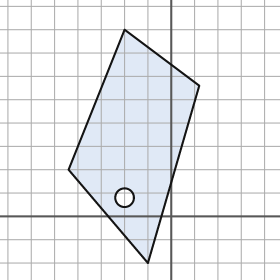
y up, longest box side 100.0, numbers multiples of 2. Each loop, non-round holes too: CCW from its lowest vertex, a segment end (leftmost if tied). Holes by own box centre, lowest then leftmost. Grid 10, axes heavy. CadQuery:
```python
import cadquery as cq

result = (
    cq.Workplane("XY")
    .moveTo(-10.0, -20.0)
    .lineTo(12.0, 56.0)
    .lineTo(-20.0, 80.0)
    .lineTo(-44.0, 20.0)
    .close()
    .moveTo(-20.0, 8.0)
    .circle(4.0)
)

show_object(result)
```